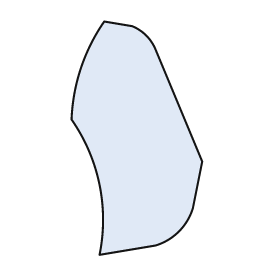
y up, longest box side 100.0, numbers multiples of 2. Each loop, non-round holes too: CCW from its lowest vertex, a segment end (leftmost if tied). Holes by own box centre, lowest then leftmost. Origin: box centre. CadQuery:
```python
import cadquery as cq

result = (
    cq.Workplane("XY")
    .moveTo(-16.0, -50.0)
    .lineTo(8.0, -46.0)
    .threePointArc((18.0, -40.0), (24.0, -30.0))
    .lineTo(28.0, -10.0)
    .lineTo(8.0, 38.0)
    .threePointArc((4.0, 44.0), (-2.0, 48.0))
    .lineTo(-14.0, 50.0)
    .threePointArc((-24.0, 30.0), (-28.0, 8.0))
    .threePointArc((-16.0, -20.0), (-16.0, -50.0))
    .close()
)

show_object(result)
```